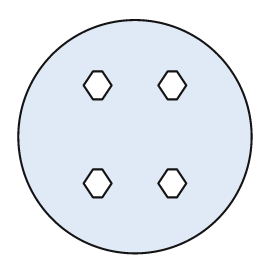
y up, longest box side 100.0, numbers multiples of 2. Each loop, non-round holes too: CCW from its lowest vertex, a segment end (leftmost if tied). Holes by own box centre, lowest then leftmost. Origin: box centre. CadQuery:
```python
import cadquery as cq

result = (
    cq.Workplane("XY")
    .moveTo(0.0, 0.0)
    .circle(50.0)
    .moveTo(-18.0, -26.0)
    .lineTo(-14.0, -26.0)
    .lineTo(-10.0, -20.0)
    .lineTo(-14.0, -14.0)
    .lineTo(-18.0, -14.0)
    .lineTo(-22.0, -20.0)
    .close()
    .moveTo(14.0, -26.0)
    .lineTo(18.0, -26.0)
    .lineTo(22.0, -20.0)
    .lineTo(18.0, -14.0)
    .lineTo(14.0, -14.0)
    .lineTo(10.0, -20.0)
    .close()
    .moveTo(-18.0, 16.0)
    .lineTo(-14.0, 16.0)
    .lineTo(-10.0, 22.0)
    .lineTo(-14.0, 28.0)
    .lineTo(-18.0, 28.0)
    .lineTo(-22.0, 22.0)
    .close()
    .moveTo(14.0, 16.0)
    .lineTo(18.0, 16.0)
    .lineTo(22.0, 22.0)
    .lineTo(18.0, 28.0)
    .lineTo(14.0, 28.0)
    .lineTo(10.0, 22.0)
    .close()
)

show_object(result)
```